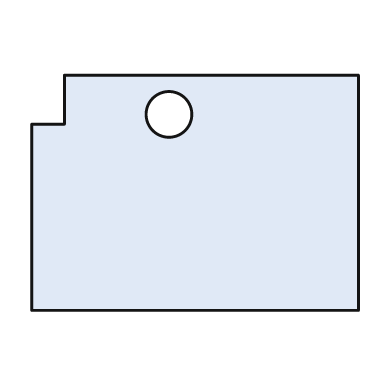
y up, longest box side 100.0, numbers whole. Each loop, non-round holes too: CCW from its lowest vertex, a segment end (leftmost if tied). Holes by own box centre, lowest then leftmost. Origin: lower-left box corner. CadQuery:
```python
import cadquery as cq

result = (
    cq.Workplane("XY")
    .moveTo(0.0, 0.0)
    .lineTo(100.0, 0.0)
    .lineTo(100.0, 72.0)
    .lineTo(10.0, 72.0)
    .lineTo(10.0, 57.0)
    .lineTo(0.0, 57.0)
    .close()
    .moveTo(42.0, 60.0)
    .circle(7.0)
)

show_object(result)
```